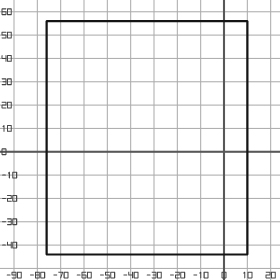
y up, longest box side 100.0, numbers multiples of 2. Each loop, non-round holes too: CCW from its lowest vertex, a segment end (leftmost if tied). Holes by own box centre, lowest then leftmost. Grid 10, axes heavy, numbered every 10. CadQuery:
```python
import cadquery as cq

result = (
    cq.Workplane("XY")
    .moveTo(-76.0, -44.0)
    .lineTo(10.0, -44.0)
    .lineTo(10.0, 56.0)
    .lineTo(-76.0, 56.0)
    .close()
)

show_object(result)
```